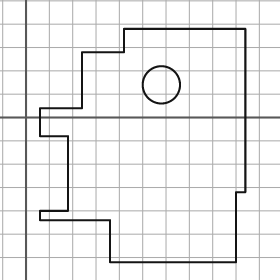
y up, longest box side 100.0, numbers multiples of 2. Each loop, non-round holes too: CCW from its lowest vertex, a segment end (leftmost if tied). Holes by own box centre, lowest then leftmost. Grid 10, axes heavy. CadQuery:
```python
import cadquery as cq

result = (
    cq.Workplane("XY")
    .moveTo(36.0, -62.0)
    .lineTo(90.0, -62.0)
    .lineTo(90.0, -32.0)
    .lineTo(94.0, -32.0)
    .lineTo(94.0, 38.0)
    .lineTo(42.0, 38.0)
    .lineTo(42.0, 28.0)
    .lineTo(24.0, 28.0)
    .lineTo(24.0, 4.0)
    .lineTo(6.0, 4.0)
    .lineTo(6.0, -8.0)
    .lineTo(18.0, -8.0)
    .lineTo(18.0, -40.0)
    .lineTo(6.0, -40.0)
    .lineTo(6.0, -44.0)
    .lineTo(36.0, -44.0)
    .close()
    .moveTo(58.0, 14.0)
    .circle(8.0)
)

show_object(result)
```